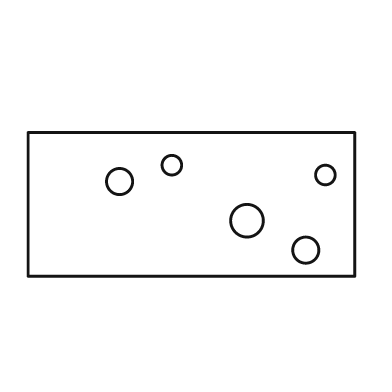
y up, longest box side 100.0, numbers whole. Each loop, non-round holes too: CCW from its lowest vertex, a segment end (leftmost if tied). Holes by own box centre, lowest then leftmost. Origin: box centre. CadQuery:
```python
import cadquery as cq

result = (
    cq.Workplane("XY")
    .moveTo(-50.0, -22.0)
    .lineTo(50.0, -22.0)
    .lineTo(50.0, 22.0)
    .lineTo(-50.0, 22.0)
    .close()
    .moveTo(35.0, -14.0)
    .circle(4.0)
    .moveTo(17.0, -5.0)
    .circle(5.0)
    .moveTo(-22.0, 7.0)
    .circle(4.0)
    .moveTo(41.0, 9.0)
    .circle(3.0)
    .moveTo(-6.0, 12.0)
    .circle(3.0)
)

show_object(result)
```